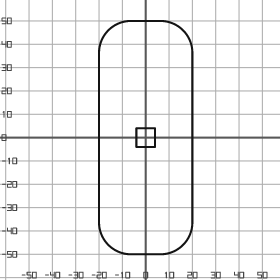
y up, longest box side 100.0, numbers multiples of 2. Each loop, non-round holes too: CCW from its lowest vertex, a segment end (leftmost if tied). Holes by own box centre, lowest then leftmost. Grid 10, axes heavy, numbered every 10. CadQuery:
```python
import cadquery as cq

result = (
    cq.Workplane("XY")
    .moveTo(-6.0, -50.0)
    .lineTo(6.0, -50.0)
    .threePointArc((16.0, -46.0), (20.0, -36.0))
    .lineTo(20.0, 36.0)
    .threePointArc((16.0, 46.0), (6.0, 50.0))
    .lineTo(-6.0, 50.0)
    .threePointArc((-16.0, 46.0), (-20.0, 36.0))
    .lineTo(-20.0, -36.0)
    .threePointArc((-16.0, -46.0), (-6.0, -50.0))
    .close()
    .moveTo(-4.0, -4.0)
    .lineTo(4.0, -4.0)
    .lineTo(4.0, 4.0)
    .lineTo(-4.0, 4.0)
    .close()
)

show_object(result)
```